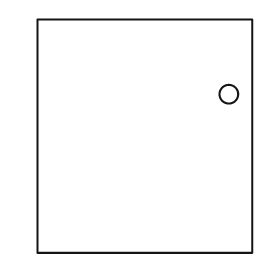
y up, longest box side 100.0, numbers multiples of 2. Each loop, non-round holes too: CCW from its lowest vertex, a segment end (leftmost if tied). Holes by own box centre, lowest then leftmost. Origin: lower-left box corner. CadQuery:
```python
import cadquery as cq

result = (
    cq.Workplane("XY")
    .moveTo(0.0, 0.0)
    .lineTo(92.0, 0.0)
    .lineTo(92.0, 100.0)
    .lineTo(0.0, 100.0)
    .close()
    .moveTo(82.0, 68.0)
    .circle(4.0)
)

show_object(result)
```